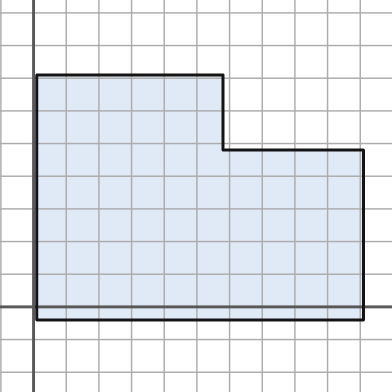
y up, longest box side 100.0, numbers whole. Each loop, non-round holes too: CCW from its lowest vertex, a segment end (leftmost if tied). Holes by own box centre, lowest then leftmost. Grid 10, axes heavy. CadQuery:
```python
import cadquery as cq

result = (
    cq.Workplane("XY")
    .moveTo(1.0, -4.0)
    .lineTo(101.0, -4.0)
    .lineTo(101.0, 48.0)
    .lineTo(58.0, 48.0)
    .lineTo(58.0, 71.0)
    .lineTo(1.0, 71.0)
    .close()
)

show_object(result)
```